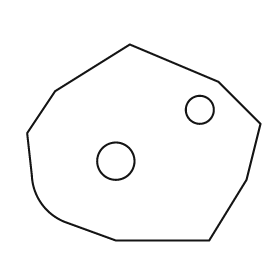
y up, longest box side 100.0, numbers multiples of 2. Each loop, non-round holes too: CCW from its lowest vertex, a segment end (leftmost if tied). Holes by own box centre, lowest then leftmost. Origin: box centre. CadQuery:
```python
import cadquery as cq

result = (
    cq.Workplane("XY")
    .moveTo(-12.0, -42.0)
    .lineTo(28.0, -42.0)
    .lineTo(44.0, -16.0)
    .lineTo(50.0, 8.0)
    .lineTo(32.0, 26.0)
    .lineTo(-6.0, 42.0)
    .lineTo(-38.0, 22.0)
    .lineTo(-50.0, 4.0)
    .lineTo(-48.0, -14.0)
    .threePointArc((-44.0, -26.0), (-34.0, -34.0))
    .close()
    .moveTo(-12.0, -8.0)
    .circle(8.0)
    .moveTo(24.0, 14.0)
    .circle(6.0)
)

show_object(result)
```